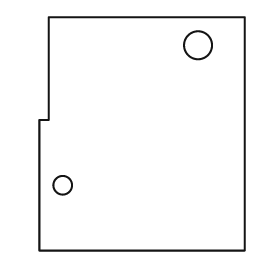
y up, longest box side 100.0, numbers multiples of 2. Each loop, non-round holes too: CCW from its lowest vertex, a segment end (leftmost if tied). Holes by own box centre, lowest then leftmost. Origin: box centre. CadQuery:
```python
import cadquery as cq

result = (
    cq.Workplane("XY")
    .moveTo(-44.0, -50.0)
    .lineTo(44.0, -50.0)
    .lineTo(44.0, 50.0)
    .lineTo(-40.0, 50.0)
    .lineTo(-40.0, 6.0)
    .lineTo(-44.0, 6.0)
    .close()
    .moveTo(-34.0, -22.0)
    .circle(4.0)
    .moveTo(24.0, 38.0)
    .circle(6.0)
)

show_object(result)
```